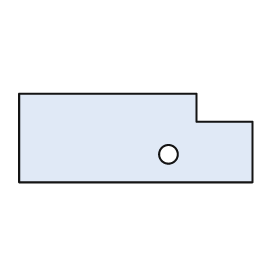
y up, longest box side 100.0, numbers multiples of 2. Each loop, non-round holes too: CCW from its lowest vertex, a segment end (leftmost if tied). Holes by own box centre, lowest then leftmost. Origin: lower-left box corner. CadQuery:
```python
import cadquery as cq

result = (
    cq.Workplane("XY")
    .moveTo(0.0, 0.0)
    .lineTo(100.0, 0.0)
    .lineTo(100.0, 26.0)
    .lineTo(76.0, 26.0)
    .lineTo(76.0, 38.0)
    .lineTo(0.0, 38.0)
    .close()
    .moveTo(64.0, 12.0)
    .circle(4.0)
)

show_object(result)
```